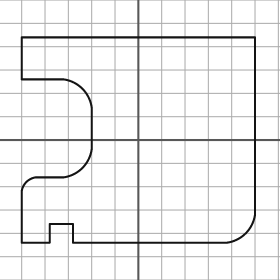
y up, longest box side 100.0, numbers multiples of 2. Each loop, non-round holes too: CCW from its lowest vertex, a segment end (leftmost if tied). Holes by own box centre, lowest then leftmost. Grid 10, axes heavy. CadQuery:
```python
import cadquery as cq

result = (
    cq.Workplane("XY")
    .moveTo(-50.0, -44.0)
    .lineTo(-38.0, -44.0)
    .lineTo(-38.0, -36.0)
    .lineTo(-28.0, -36.0)
    .lineTo(-28.0, -44.0)
    .lineTo(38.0, -44.0)
    .threePointArc((46.0, -40.0), (50.0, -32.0))
    .lineTo(50.0, 44.0)
    .lineTo(-50.0, 44.0)
    .lineTo(-50.0, 26.0)
    .lineTo(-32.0, 26.0)
    .threePointArc((-24.0, 22.0), (-20.0, 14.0))
    .lineTo(-20.0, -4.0)
    .threePointArc((-24.0, -12.0), (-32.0, -16.0))
    .lineTo(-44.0, -16.0)
    .threePointArc((-48.0, -18.0), (-50.0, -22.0))
    .close()
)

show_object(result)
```